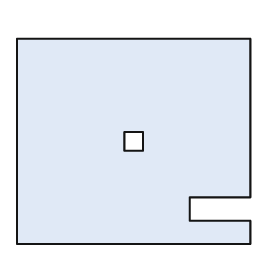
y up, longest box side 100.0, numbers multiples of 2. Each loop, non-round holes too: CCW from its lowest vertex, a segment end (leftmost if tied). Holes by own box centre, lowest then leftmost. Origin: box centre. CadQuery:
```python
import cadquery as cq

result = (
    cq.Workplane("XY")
    .moveTo(-50.0, -44.0)
    .lineTo(50.0, -44.0)
    .lineTo(50.0, -34.0)
    .lineTo(24.0, -34.0)
    .lineTo(24.0, -24.0)
    .lineTo(50.0, -24.0)
    .lineTo(50.0, 44.0)
    .lineTo(-50.0, 44.0)
    .close()
    .moveTo(-4.0, -4.0)
    .lineTo(4.0, -4.0)
    .lineTo(4.0, 4.0)
    .lineTo(-4.0, 4.0)
    .close()
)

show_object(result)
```